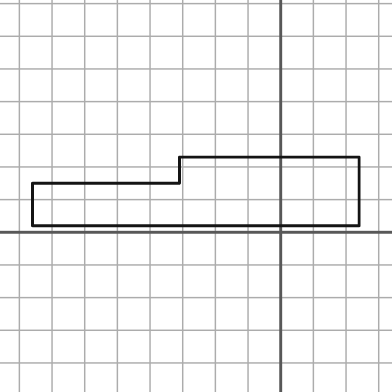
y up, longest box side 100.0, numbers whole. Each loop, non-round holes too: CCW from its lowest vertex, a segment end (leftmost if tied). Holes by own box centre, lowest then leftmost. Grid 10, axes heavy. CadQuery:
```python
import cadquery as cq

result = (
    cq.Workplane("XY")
    .moveTo(-76.0, 2.0)
    .lineTo(24.0, 2.0)
    .lineTo(24.0, 23.0)
    .lineTo(-31.0, 23.0)
    .lineTo(-31.0, 15.0)
    .lineTo(-76.0, 15.0)
    .close()
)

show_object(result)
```